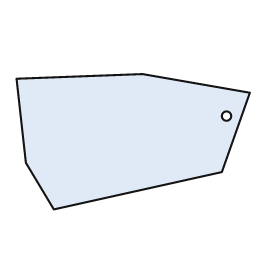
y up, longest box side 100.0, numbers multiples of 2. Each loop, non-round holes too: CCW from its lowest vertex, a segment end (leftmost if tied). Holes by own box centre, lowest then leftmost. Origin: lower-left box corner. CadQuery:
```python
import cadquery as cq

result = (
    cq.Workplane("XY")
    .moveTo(16.0, 0.0)
    .lineTo(88.0, 16.0)
    .lineTo(100.0, 50.0)
    .lineTo(54.0, 58.0)
    .lineTo(0.0, 56.0)
    .lineTo(4.0, 20.0)
    .close()
    .moveTo(90.0, 40.0)
    .circle(2.0)
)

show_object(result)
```